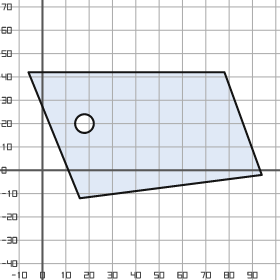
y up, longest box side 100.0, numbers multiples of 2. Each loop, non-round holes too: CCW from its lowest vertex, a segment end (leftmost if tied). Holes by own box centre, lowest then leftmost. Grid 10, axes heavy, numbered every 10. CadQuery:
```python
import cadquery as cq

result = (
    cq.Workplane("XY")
    .moveTo(16.0, -12.0)
    .lineTo(94.0, -2.0)
    .lineTo(78.0, 42.0)
    .lineTo(-6.0, 42.0)
    .close()
    .moveTo(18.0, 20.0)
    .circle(4.0)
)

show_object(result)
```